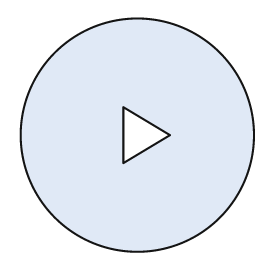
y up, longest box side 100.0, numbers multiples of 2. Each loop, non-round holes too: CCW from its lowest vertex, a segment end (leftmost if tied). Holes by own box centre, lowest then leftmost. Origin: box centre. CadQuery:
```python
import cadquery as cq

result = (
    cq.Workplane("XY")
    .moveTo(0.0, 0.0)
    .circle(50.0)
    .moveTo(-6.0, -12.0)
    .lineTo(14.0, 0.0)
    .lineTo(-6.0, 12.0)
    .close()
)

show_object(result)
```